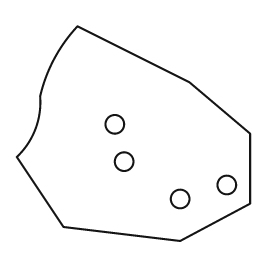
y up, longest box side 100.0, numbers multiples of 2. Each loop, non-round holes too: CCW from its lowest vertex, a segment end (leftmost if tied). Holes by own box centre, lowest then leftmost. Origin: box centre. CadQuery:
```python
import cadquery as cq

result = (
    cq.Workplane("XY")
    .moveTo(20.0, -46.0)
    .lineTo(50.0, -30.0)
    .lineTo(50.0, 0.0)
    .lineTo(24.0, 22.0)
    .lineTo(-24.0, 46.0)
    .threePointArc((-34.0, 32.0), (-40.0, 16.0))
    .threePointArc((-42.0, 2.0), (-50.0, -10.0))
    .lineTo(-30.0, -40.0)
    .close()
    .moveTo(20.0, -28.0)
    .circle(4.0)
    .moveTo(40.0, -22.0)
    .circle(4.0)
    .moveTo(-4.0, -12.0)
    .circle(4.0)
    .moveTo(-8.0, 4.0)
    .circle(4.0)
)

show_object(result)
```